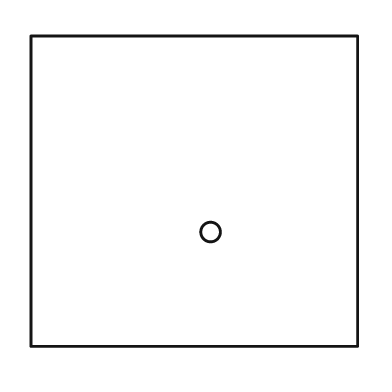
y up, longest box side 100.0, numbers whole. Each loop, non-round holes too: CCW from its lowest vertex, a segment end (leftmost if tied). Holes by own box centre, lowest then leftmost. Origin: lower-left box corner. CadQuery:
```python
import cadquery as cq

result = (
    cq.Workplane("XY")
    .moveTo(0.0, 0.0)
    .lineTo(100.0, 0.0)
    .lineTo(100.0, 95.0)
    .lineTo(0.0, 95.0)
    .close()
    .moveTo(55.0, 35.0)
    .circle(3.0)
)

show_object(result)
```